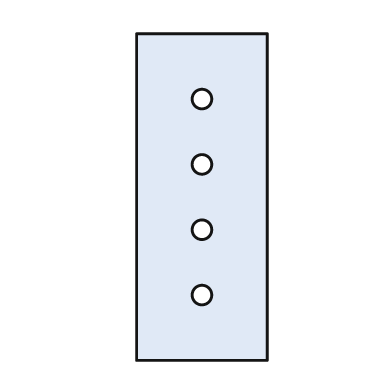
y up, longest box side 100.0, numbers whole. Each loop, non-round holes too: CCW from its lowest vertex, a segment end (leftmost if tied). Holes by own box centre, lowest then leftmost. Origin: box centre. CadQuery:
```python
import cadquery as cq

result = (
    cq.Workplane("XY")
    .moveTo(-20.0, -50.0)
    .lineTo(20.0, -50.0)
    .lineTo(20.0, 50.0)
    .lineTo(-20.0, 50.0)
    .close()
    .moveTo(0.0, -30.0)
    .circle(3.0)
    .moveTo(0.0, -10.0)
    .circle(3.0)
    .moveTo(0.0, 10.0)
    .circle(3.0)
    .moveTo(0.0, 30.0)
    .circle(3.0)
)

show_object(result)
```